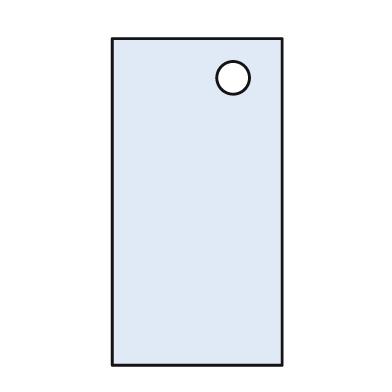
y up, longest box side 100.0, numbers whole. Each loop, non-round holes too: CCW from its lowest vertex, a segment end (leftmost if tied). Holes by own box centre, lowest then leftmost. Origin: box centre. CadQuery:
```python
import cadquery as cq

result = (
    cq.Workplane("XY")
    .moveTo(-26.0, -50.0)
    .lineTo(26.0, -50.0)
    .lineTo(26.0, 50.0)
    .lineTo(-26.0, 50.0)
    .close()
    .moveTo(11.0, 38.0)
    .circle(5.0)
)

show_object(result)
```